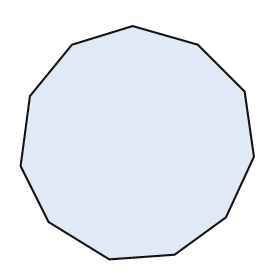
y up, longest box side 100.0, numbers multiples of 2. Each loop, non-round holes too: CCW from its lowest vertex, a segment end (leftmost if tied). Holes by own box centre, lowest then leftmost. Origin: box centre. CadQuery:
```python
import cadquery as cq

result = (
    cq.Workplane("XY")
    .moveTo(-12.0, -50.0)
    .lineTo(16.0, -48.0)
    .lineTo(38.0, -32.0)
    .lineTo(50.0, -6.0)
    .lineTo(46.0, 22.0)
    .lineTo(26.0, 42.0)
    .lineTo(-2.0, 50.0)
    .lineTo(-28.0, 42.0)
    .lineTo(-46.0, 20.0)
    .lineTo(-50.0, -10.0)
    .lineTo(-38.0, -34.0)
    .close()
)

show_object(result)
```